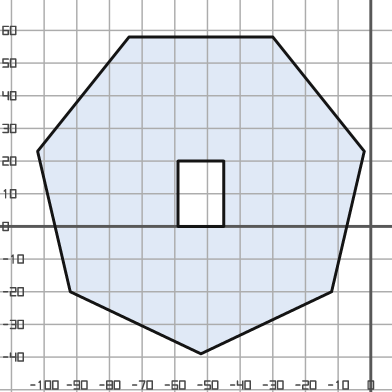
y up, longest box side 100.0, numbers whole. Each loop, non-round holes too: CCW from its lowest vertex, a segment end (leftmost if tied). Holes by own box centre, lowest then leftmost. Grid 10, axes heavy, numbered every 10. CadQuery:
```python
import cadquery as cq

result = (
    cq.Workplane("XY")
    .moveTo(-52.0, -39.0)
    .lineTo(-12.0, -20.0)
    .lineTo(-2.0, 23.0)
    .lineTo(-30.0, 58.0)
    .lineTo(-74.0, 58.0)
    .lineTo(-102.0, 23.0)
    .lineTo(-92.0, -20.0)
    .close()
    .moveTo(-59.0, 0.0)
    .lineTo(-45.0, 0.0)
    .lineTo(-45.0, 20.0)
    .lineTo(-59.0, 20.0)
    .close()
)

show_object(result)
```